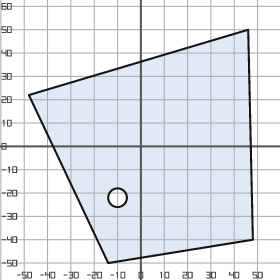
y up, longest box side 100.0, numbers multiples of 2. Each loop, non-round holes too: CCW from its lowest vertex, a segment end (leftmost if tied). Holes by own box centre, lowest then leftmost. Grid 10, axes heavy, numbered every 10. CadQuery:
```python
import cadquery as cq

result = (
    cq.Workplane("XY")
    .moveTo(-14.0, -50.0)
    .lineTo(48.0, -40.0)
    .lineTo(46.0, 50.0)
    .lineTo(-48.0, 22.0)
    .close()
    .moveTo(-10.0, -22.0)
    .circle(4.0)
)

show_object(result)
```